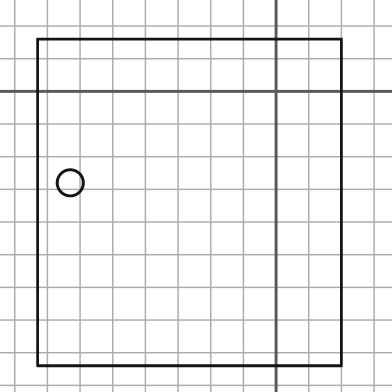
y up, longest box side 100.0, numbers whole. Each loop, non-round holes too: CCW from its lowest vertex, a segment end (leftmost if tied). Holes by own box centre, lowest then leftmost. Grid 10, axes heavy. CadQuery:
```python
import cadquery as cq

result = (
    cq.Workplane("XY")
    .moveTo(-73.0, -84.0)
    .lineTo(20.0, -84.0)
    .lineTo(20.0, 16.0)
    .lineTo(-73.0, 16.0)
    .close()
    .moveTo(-63.0, -28.0)
    .circle(4.0)
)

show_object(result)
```